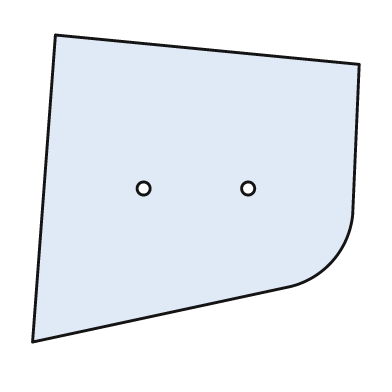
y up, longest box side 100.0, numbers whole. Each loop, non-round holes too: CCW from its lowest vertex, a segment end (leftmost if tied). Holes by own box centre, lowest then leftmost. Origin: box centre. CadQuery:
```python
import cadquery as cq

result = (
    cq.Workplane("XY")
    .moveTo(-50.0, -47.0)
    .lineTo(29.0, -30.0)
    .threePointArc((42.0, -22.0), (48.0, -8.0))
    .lineTo(50.0, 38.0)
    .lineTo(-43.0, 47.0)
    .close()
    .moveTo(-16.0, 0.0)
    .circle(2.0)
    .moveTo(16.0, 0.0)
    .circle(2.0)
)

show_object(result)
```